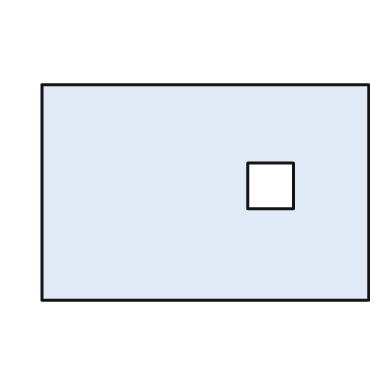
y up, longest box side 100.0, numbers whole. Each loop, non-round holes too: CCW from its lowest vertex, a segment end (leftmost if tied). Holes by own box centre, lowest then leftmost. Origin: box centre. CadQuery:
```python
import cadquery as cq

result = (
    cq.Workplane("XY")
    .moveTo(-50.0, -33.0)
    .lineTo(50.0, -33.0)
    .lineTo(50.0, 33.0)
    .lineTo(-50.0, 33.0)
    .close()
    .moveTo(13.0, -5.0)
    .lineTo(27.0, -5.0)
    .lineTo(27.0, 9.0)
    .lineTo(13.0, 9.0)
    .close()
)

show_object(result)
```